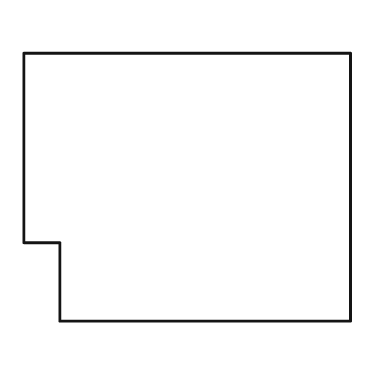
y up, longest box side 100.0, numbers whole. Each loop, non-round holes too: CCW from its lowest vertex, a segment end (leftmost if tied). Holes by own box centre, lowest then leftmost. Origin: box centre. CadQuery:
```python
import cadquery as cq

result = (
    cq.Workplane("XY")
    .moveTo(-39.0, -41.0)
    .lineTo(50.0, -41.0)
    .lineTo(50.0, 41.0)
    .lineTo(-50.0, 41.0)
    .lineTo(-50.0, -17.0)
    .lineTo(-39.0, -17.0)
    .close()
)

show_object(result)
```